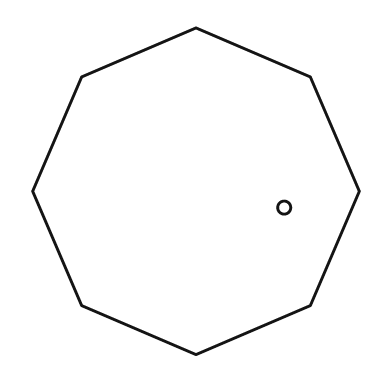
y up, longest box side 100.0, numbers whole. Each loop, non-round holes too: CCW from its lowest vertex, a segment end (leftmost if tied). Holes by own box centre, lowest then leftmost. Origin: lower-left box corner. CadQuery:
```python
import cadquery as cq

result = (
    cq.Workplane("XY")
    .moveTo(50.0, 0.0)
    .lineTo(85.0, 15.0)
    .lineTo(100.0, 50.0)
    .lineTo(85.0, 85.0)
    .lineTo(50.0, 100.0)
    .lineTo(15.0, 85.0)
    .lineTo(0.0, 50.0)
    .lineTo(15.0, 15.0)
    .close()
    .moveTo(77.0, 45.0)
    .circle(2.0)
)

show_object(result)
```